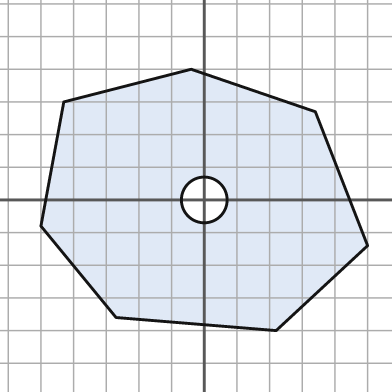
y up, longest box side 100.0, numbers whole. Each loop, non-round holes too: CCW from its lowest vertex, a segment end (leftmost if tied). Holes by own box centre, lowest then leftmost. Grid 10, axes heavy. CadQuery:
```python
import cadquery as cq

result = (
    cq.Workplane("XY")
    .moveTo(22.0, -40.0)
    .lineTo(50.0, -14.0)
    .lineTo(34.0, 27.0)
    .lineTo(-4.0, 40.0)
    .lineTo(-43.0, 30.0)
    .lineTo(-50.0, -8.0)
    .lineTo(-27.0, -36.0)
    .close()
    .moveTo(0.0, 0.0)
    .circle(7.0)
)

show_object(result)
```